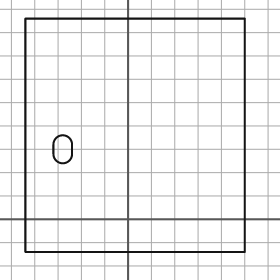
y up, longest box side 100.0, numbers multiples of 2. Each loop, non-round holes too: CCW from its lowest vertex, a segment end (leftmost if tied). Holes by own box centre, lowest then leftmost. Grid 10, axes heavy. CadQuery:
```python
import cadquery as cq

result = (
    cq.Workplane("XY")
    .moveTo(-44.0, -14.0)
    .lineTo(50.0, -14.0)
    .lineTo(50.0, 86.0)
    .lineTo(-44.0, 86.0)
    .close()
    .moveTo(-32.0, 28.0)
    .threePointArc((-28.0, 24.0), (-24.0, 28.0))
    .lineTo(-24.0, 32.0)
    .threePointArc((-28.0, 36.0), (-32.0, 32.0))
    .close()
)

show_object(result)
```